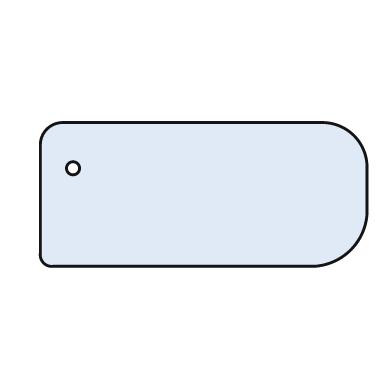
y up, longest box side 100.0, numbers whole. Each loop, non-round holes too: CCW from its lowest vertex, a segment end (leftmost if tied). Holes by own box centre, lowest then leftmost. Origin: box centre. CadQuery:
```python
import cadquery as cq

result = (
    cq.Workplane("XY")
    .moveTo(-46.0, -22.0)
    .lineTo(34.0, -22.0)
    .threePointArc((45.0, -17.0), (50.0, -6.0))
    .lineTo(50.0, 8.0)
    .threePointArc((46.0, 18.0), (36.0, 22.0))
    .lineTo(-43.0, 22.0)
    .threePointArc((-48.0, 20.0), (-50.0, 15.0))
    .lineTo(-50.0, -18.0)
    .threePointArc((-49.0, -21.0), (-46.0, -22.0))
    .close()
    .moveTo(-40.0, 8.0)
    .circle(2.0)
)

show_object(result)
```